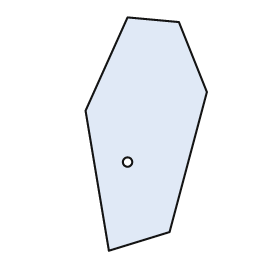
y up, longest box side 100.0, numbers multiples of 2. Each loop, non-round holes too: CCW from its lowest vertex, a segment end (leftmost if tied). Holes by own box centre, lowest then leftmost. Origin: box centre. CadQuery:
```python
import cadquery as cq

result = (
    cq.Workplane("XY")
    .moveTo(-16.0, -50.0)
    .lineTo(10.0, -42.0)
    .lineTo(26.0, 18.0)
    .lineTo(14.0, 48.0)
    .lineTo(-8.0, 50.0)
    .lineTo(-26.0, 10.0)
    .close()
    .moveTo(-8.0, -12.0)
    .circle(2.0)
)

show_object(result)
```